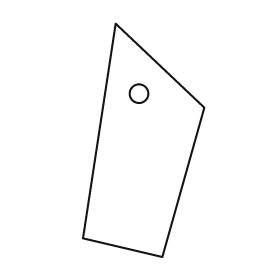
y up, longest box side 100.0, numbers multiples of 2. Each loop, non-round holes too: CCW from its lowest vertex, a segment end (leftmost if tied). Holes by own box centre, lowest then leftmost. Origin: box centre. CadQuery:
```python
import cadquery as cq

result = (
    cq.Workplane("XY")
    .moveTo(8.0, -50.0)
    .lineTo(26.0, 14.0)
    .lineTo(-12.0, 50.0)
    .lineTo(-26.0, -42.0)
    .close()
    .moveTo(-2.0, 20.0)
    .circle(4.0)
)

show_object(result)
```